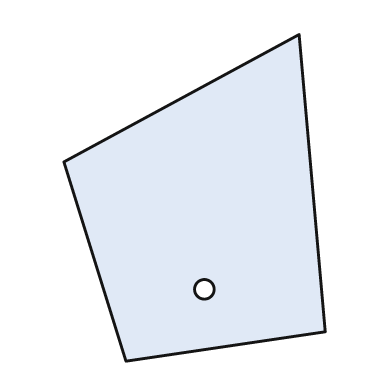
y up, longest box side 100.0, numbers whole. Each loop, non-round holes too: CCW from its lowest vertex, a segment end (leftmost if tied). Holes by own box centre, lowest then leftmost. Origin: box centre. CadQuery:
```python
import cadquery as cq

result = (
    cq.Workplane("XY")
    .moveTo(-21.0, -50.0)
    .lineTo(40.0, -41.0)
    .lineTo(32.0, 50.0)
    .lineTo(-40.0, 11.0)
    .close()
    .moveTo(3.0, -28.0)
    .circle(3.0)
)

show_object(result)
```